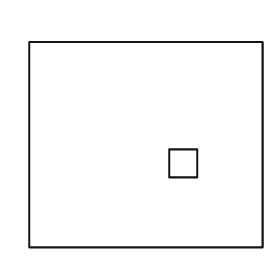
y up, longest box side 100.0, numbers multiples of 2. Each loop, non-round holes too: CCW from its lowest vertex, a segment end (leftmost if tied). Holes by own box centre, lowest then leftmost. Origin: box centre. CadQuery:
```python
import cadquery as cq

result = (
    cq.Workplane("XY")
    .moveTo(-50.0, -44.0)
    .lineTo(50.0, -44.0)
    .lineTo(50.0, 44.0)
    .lineTo(-50.0, 44.0)
    .close()
    .moveTo(10.0, -14.0)
    .lineTo(22.0, -14.0)
    .lineTo(22.0, -2.0)
    .lineTo(10.0, -2.0)
    .close()
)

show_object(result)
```